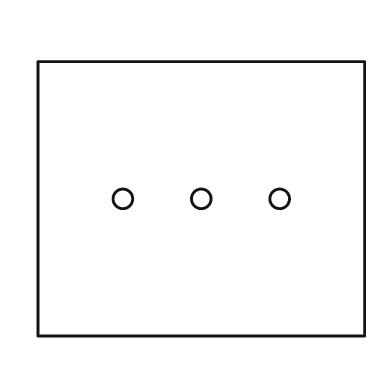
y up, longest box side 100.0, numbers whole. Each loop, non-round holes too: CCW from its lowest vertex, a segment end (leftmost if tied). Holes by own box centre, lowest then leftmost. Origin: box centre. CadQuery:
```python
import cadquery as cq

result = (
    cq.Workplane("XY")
    .moveTo(-50.0, -42.0)
    .lineTo(50.0, -42.0)
    .lineTo(50.0, 42.0)
    .lineTo(-50.0, 42.0)
    .close()
    .moveTo(-24.0, 0.0)
    .circle(3.0)
    .moveTo(0.0, 0.0)
    .circle(3.0)
    .moveTo(24.0, 0.0)
    .circle(3.0)
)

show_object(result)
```